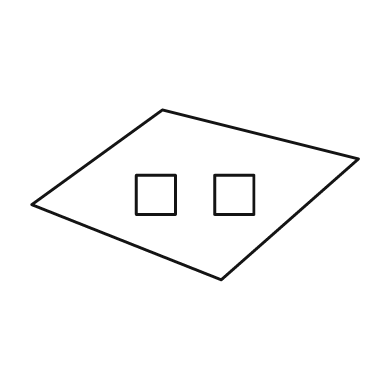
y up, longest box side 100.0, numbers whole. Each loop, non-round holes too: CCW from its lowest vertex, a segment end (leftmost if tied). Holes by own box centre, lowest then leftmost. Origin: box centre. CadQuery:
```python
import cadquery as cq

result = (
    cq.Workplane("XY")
    .moveTo(8.0, -26.0)
    .lineTo(50.0, 11.0)
    .lineTo(-10.0, 26.0)
    .lineTo(-50.0, -3.0)
    .close()
    .moveTo(-18.0, -6.0)
    .lineTo(-6.0, -6.0)
    .lineTo(-6.0, 6.0)
    .lineTo(-18.0, 6.0)
    .close()
    .moveTo(6.0, -6.0)
    .lineTo(18.0, -6.0)
    .lineTo(18.0, 6.0)
    .lineTo(6.0, 6.0)
    .close()
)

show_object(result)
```